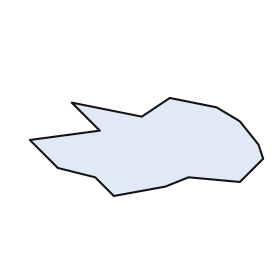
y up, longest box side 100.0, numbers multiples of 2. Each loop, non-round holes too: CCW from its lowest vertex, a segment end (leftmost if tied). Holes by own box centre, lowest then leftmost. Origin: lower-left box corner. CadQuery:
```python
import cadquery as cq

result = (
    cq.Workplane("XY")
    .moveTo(36.0, 0.0)
    .lineTo(58.0, 4.0)
    .lineTo(68.0, 8.0)
    .lineTo(90.0, 6.0)
    .lineTo(100.0, 16.0)
    .lineTo(98.0, 22.0)
    .lineTo(90.0, 32.0)
    .lineTo(80.0, 38.0)
    .lineTo(60.0, 42.0)
    .lineTo(48.0, 34.0)
    .lineTo(18.0, 40.0)
    .lineTo(30.0, 28.0)
    .lineTo(0.0, 24.0)
    .lineTo(12.0, 12.0)
    .lineTo(28.0, 8.0)
    .close()
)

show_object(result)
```